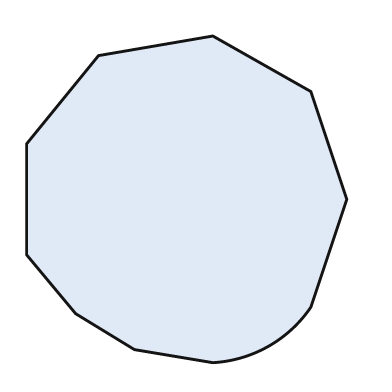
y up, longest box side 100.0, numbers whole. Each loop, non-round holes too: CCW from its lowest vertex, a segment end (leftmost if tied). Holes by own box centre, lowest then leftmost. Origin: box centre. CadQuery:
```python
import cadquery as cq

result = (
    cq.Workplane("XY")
    .moveTo(8.0, -50.0)
    .threePointArc((25.0, -45.0), (38.0, -33.0))
    .lineTo(49.0, 0.0)
    .lineTo(38.0, 33.0)
    .lineTo(8.0, 50.0)
    .lineTo(-27.0, 44.0)
    .lineTo(-49.0, 17.0)
    .lineTo(-49.0, -17.0)
    .lineTo(-34.0, -35.0)
    .lineTo(-16.0, -46.0)
    .close()
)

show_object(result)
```